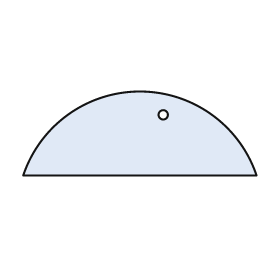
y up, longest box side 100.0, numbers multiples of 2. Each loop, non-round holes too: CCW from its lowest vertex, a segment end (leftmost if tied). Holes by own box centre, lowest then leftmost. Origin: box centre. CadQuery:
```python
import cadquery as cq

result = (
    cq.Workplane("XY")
    .moveTo(-50.0, -18.0)
    .lineTo(50.0, -18.0)
    .threePointArc((0.0, 18.0), (-50.0, -18.0))
    .close()
    .moveTo(10.0, 8.0)
    .circle(2.0)
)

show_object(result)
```